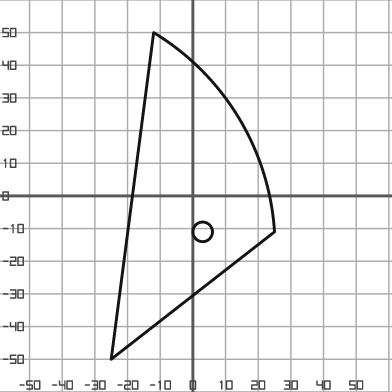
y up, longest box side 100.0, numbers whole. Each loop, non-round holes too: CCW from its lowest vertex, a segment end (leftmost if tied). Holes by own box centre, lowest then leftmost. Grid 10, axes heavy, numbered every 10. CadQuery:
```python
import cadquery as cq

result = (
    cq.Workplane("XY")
    .moveTo(-25.0, -50.0)
    .lineTo(25.0, -11.0)
    .threePointArc((14.0, 24.0), (-12.0, 50.0))
    .close()
    .moveTo(3.0, -11.0)
    .circle(3.0)
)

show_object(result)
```